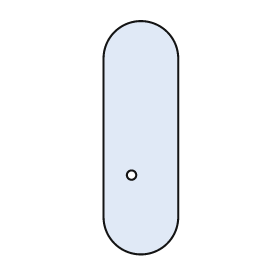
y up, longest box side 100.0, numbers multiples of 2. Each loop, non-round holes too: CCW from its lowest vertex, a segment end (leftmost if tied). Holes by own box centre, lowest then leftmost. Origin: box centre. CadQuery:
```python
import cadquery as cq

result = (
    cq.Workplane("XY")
    .moveTo(-16.0, -34.0)
    .threePointArc((0.0, -50.0), (16.0, -34.0))
    .lineTo(16.0, 34.0)
    .threePointArc((0.0, 50.0), (-16.0, 34.0))
    .close()
    .moveTo(-4.0, -16.0)
    .circle(2.0)
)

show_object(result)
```